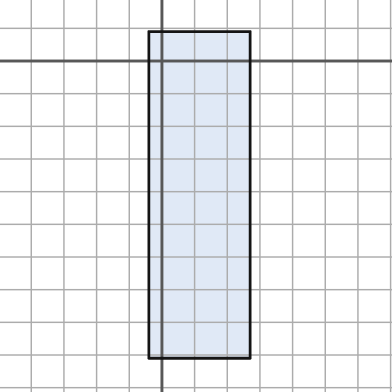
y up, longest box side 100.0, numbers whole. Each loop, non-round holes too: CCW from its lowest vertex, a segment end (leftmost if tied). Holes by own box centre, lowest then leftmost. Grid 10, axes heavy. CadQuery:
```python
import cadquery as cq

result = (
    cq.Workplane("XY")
    .moveTo(-4.0, -91.0)
    .lineTo(27.0, -91.0)
    .lineTo(27.0, 9.0)
    .lineTo(-4.0, 9.0)
    .close()
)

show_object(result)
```